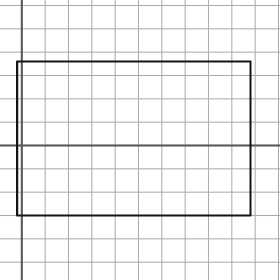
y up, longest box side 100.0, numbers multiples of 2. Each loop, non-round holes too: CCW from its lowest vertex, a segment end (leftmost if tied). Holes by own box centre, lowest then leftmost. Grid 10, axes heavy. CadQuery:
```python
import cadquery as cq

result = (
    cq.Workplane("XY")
    .moveTo(-2.0, -30.0)
    .lineTo(98.0, -30.0)
    .lineTo(98.0, 36.0)
    .lineTo(-2.0, 36.0)
    .close()
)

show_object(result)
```